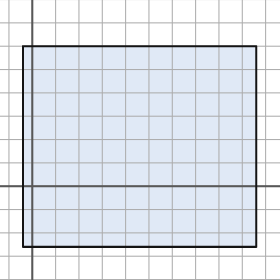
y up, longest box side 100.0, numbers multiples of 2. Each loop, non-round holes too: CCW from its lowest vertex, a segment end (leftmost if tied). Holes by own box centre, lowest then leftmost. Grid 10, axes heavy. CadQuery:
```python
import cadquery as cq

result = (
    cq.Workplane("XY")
    .moveTo(-4.0, -26.0)
    .lineTo(96.0, -26.0)
    .lineTo(96.0, 60.0)
    .lineTo(-4.0, 60.0)
    .close()
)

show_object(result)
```